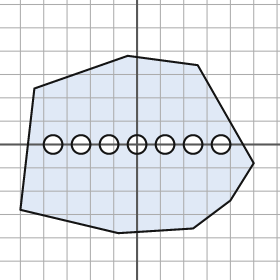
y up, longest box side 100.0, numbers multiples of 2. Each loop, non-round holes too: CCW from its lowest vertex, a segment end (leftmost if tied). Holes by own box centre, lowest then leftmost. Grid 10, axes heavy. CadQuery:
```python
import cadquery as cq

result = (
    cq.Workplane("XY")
    .moveTo(-8.0, -38.0)
    .lineTo(24.0, -36.0)
    .lineTo(40.0, -24.0)
    .lineTo(50.0, -8.0)
    .lineTo(26.0, 34.0)
    .lineTo(-4.0, 38.0)
    .lineTo(-44.0, 24.0)
    .lineTo(-50.0, -28.0)
    .close()
    .moveTo(-36.0, 0.0)
    .circle(4.0)
    .moveTo(-24.0, 0.0)
    .circle(4.0)
    .moveTo(-12.0, 0.0)
    .circle(4.0)
    .moveTo(0.0, 0.0)
    .circle(4.0)
    .moveTo(12.0, 0.0)
    .circle(4.0)
    .moveTo(24.0, 0.0)
    .circle(4.0)
    .moveTo(36.0, 0.0)
    .circle(4.0)
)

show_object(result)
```